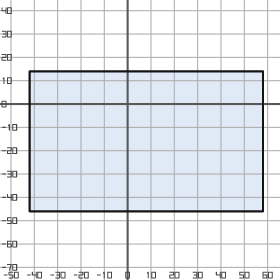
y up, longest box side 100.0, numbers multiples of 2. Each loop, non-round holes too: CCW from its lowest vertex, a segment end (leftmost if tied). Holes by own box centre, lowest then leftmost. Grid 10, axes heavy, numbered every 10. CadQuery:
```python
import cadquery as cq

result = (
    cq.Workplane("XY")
    .moveTo(-42.0, -46.0)
    .lineTo(58.0, -46.0)
    .lineTo(58.0, 14.0)
    .lineTo(-42.0, 14.0)
    .close()
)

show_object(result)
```